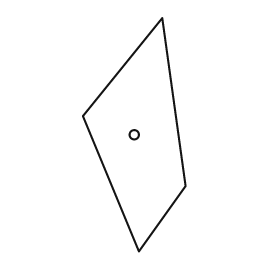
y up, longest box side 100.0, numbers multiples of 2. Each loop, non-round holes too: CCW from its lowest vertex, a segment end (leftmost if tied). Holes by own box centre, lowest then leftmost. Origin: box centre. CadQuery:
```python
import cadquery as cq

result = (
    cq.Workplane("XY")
    .moveTo(2.0, -50.0)
    .lineTo(22.0, -22.0)
    .lineTo(12.0, 50.0)
    .lineTo(-22.0, 8.0)
    .close()
    .moveTo(0.0, 0.0)
    .circle(2.0)
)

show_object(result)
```